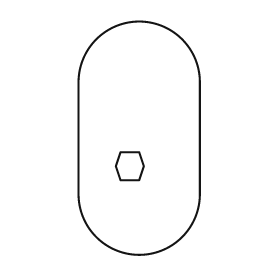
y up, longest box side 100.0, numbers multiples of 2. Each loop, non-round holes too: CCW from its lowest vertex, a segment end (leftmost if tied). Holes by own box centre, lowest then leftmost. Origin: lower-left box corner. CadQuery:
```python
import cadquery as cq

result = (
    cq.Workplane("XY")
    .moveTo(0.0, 26.0)
    .threePointArc((26.0, 0.0), (52.0, 26.0))
    .lineTo(52.0, 74.0)
    .threePointArc((26.0, 100.0), (0.0, 74.0))
    .close()
    .moveTo(18.0, 32.0)
    .lineTo(26.0, 32.0)
    .lineTo(28.0, 38.0)
    .lineTo(26.0, 44.0)
    .lineTo(18.0, 44.0)
    .lineTo(16.0, 38.0)
    .close()
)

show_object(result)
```